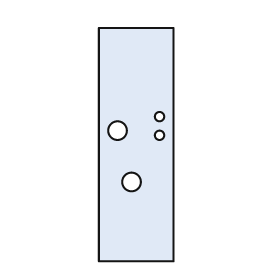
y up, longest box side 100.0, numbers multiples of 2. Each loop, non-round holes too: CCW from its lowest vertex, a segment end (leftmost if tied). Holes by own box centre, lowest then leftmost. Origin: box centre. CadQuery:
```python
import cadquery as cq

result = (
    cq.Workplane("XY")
    .moveTo(-16.0, -50.0)
    .lineTo(16.0, -50.0)
    .lineTo(16.0, 50.0)
    .lineTo(-16.0, 50.0)
    .close()
    .moveTo(-2.0, -16.0)
    .circle(4.0)
    .moveTo(10.0, 4.0)
    .circle(2.0)
    .moveTo(-8.0, 6.0)
    .circle(4.0)
    .moveTo(10.0, 12.0)
    .circle(2.0)
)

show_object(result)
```